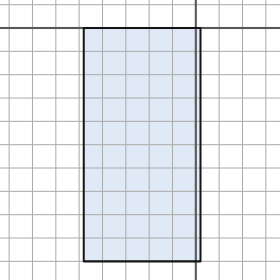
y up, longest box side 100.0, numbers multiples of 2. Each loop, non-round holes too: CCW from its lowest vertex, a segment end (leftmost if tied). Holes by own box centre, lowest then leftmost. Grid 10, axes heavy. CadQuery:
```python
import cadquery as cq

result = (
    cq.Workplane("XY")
    .moveTo(-48.0, -100.0)
    .lineTo(2.0, -100.0)
    .lineTo(2.0, 0.0)
    .lineTo(-48.0, 0.0)
    .close()
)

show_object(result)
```